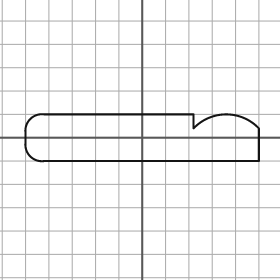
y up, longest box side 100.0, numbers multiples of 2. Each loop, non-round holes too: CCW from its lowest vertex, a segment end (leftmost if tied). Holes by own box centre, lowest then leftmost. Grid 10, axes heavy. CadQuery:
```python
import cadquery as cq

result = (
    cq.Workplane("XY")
    .moveTo(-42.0, -10.0)
    .lineTo(50.0, -10.0)
    .lineTo(50.0, 4.0)
    .threePointArc((36.0, 10.0), (22.0, 4.0))
    .lineTo(22.0, 10.0)
    .lineTo(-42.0, 10.0)
    .threePointArc((-48.0, 8.0), (-50.0, 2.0))
    .lineTo(-50.0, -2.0)
    .threePointArc((-48.0, -8.0), (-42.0, -10.0))
    .close()
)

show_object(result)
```